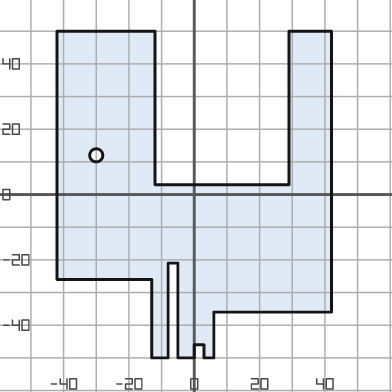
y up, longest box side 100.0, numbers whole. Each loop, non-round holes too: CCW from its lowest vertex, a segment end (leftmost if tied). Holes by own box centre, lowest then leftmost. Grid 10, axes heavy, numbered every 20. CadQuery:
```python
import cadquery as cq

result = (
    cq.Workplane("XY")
    .moveTo(-13.0, -50.0)
    .lineTo(-8.0, -50.0)
    .lineTo(-8.0, -21.0)
    .lineTo(-5.0, -21.0)
    .lineTo(-5.0, -50.0)
    .lineTo(0.0, -50.0)
    .lineTo(0.0, -46.0)
    .lineTo(3.0, -46.0)
    .lineTo(3.0, -50.0)
    .lineTo(6.0, -50.0)
    .lineTo(6.0, -36.0)
    .lineTo(42.0, -36.0)
    .lineTo(42.0, 50.0)
    .lineTo(29.0, 50.0)
    .lineTo(29.0, 3.0)
    .lineTo(-12.0, 3.0)
    .lineTo(-12.0, 50.0)
    .lineTo(-42.0, 50.0)
    .lineTo(-42.0, -26.0)
    .lineTo(-13.0, -26.0)
    .close()
    .moveTo(-30.0, 12.0)
    .circle(2.0)
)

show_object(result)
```